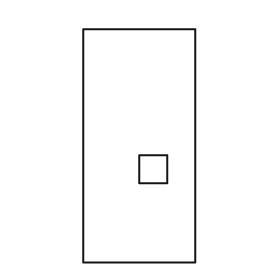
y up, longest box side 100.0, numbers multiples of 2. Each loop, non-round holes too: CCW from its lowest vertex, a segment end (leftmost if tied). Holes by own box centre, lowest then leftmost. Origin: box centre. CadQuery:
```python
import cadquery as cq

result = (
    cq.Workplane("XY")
    .moveTo(-24.0, -50.0)
    .lineTo(24.0, -50.0)
    .lineTo(24.0, 50.0)
    .lineTo(-24.0, 50.0)
    .close()
    .moveTo(0.0, -16.0)
    .lineTo(12.0, -16.0)
    .lineTo(12.0, -4.0)
    .lineTo(0.0, -4.0)
    .close()
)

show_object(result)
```